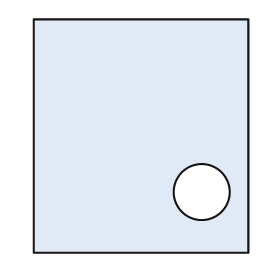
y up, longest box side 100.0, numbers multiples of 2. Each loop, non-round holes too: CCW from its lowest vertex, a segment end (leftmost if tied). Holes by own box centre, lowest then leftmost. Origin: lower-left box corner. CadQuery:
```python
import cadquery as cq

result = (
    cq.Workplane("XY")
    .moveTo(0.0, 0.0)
    .lineTo(92.0, 0.0)
    .lineTo(92.0, 100.0)
    .lineTo(0.0, 100.0)
    .close()
    .moveTo(72.0, 26.0)
    .circle(12.0)
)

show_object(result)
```